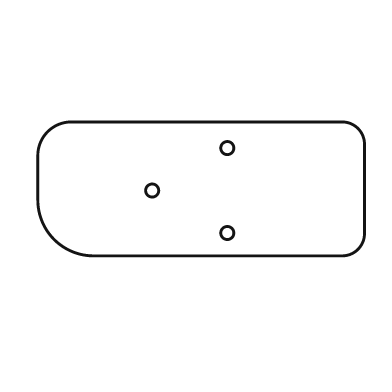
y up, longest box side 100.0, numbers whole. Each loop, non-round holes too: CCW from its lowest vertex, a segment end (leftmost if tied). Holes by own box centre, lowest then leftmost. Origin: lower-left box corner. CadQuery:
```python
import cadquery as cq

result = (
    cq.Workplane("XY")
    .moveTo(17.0, 0.0)
    .lineTo(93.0, 0.0)
    .threePointArc((98.0, 2.0), (100.0, 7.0))
    .lineTo(100.0, 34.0)
    .threePointArc((98.0, 39.0), (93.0, 41.0))
    .lineTo(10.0, 41.0)
    .threePointArc((3.0, 38.0), (0.0, 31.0))
    .lineTo(0.0, 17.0)
    .threePointArc((5.0, 5.0), (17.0, 0.0))
    .close()
    .moveTo(58.0, 7.0)
    .circle(2.0)
    .moveTo(35.0, 20.0)
    .circle(2.0)
    .moveTo(58.0, 33.0)
    .circle(2.0)
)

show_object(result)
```